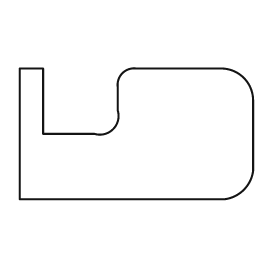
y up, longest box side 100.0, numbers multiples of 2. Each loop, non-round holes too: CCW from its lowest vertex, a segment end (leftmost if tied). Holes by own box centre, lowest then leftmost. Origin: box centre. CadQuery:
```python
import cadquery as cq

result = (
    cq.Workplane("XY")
    .moveTo(-50.0, -28.0)
    .lineTo(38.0, -28.0)
    .threePointArc((46.0, -24.0), (50.0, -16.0))
    .lineTo(50.0, 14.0)
    .threePointArc((46.0, 24.0), (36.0, 28.0))
    .lineTo(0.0, 28.0)
    .threePointArc((-6.0, 26.0), (-8.0, 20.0))
    .lineTo(-8.0, 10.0)
    .threePointArc((-10.0, 2.0), (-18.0, 0.0))
    .lineTo(-40.0, 0.0)
    .lineTo(-40.0, 28.0)
    .lineTo(-50.0, 28.0)
    .close()
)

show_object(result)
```